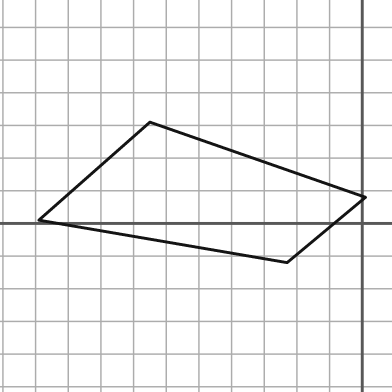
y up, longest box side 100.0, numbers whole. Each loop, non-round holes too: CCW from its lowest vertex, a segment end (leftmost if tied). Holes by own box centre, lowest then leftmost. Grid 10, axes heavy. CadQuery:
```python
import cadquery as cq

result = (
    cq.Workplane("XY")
    .moveTo(-23.0, -12.0)
    .lineTo(1.0, 8.0)
    .lineTo(-65.0, 31.0)
    .lineTo(-99.0, 1.0)
    .close()
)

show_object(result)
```